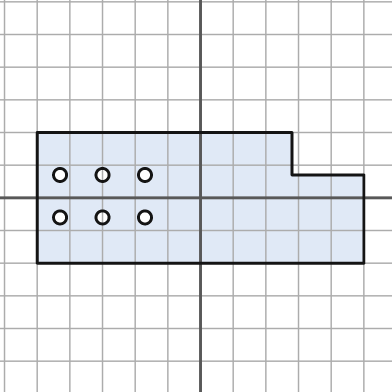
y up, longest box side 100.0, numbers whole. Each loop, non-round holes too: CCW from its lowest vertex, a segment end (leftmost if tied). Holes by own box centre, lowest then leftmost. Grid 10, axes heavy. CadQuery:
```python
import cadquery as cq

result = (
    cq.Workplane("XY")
    .moveTo(-50.0, -20.0)
    .lineTo(50.0, -20.0)
    .lineTo(50.0, 7.0)
    .lineTo(28.0, 7.0)
    .lineTo(28.0, 20.0)
    .lineTo(-50.0, 20.0)
    .close()
    .moveTo(-43.0, -6.0)
    .circle(2.0)
    .moveTo(-30.0, -6.0)
    .circle(2.0)
    .moveTo(-17.0, -6.0)
    .circle(2.0)
    .moveTo(-43.0, 7.0)
    .circle(2.0)
    .moveTo(-30.0, 7.0)
    .circle(2.0)
    .moveTo(-17.0, 7.0)
    .circle(2.0)
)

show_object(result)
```